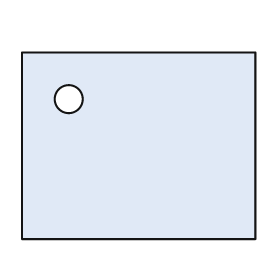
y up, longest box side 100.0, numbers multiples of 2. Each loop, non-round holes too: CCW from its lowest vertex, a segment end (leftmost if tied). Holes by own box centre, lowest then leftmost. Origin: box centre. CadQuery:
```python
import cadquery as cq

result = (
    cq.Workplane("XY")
    .moveTo(-50.0, -40.0)
    .lineTo(50.0, -40.0)
    .lineTo(50.0, 40.0)
    .lineTo(-50.0, 40.0)
    .close()
    .moveTo(-30.0, 20.0)
    .circle(6.0)
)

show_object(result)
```